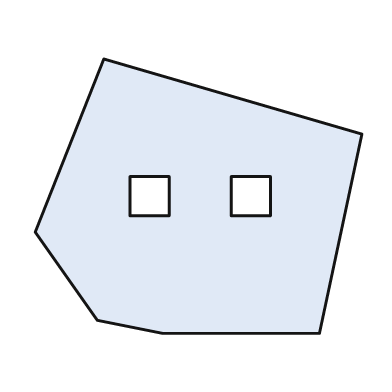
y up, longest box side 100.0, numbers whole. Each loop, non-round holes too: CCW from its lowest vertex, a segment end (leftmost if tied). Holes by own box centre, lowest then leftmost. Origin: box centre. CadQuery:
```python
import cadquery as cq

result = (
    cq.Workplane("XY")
    .moveTo(-11.0, -42.0)
    .lineTo(37.0, -42.0)
    .lineTo(50.0, 19.0)
    .lineTo(-29.0, 42.0)
    .lineTo(-50.0, -11.0)
    .lineTo(-31.0, -38.0)
    .close()
    .moveTo(-21.0, -6.0)
    .lineTo(-9.0, -6.0)
    .lineTo(-9.0, 6.0)
    .lineTo(-21.0, 6.0)
    .close()
    .moveTo(10.0, -6.0)
    .lineTo(22.0, -6.0)
    .lineTo(22.0, 6.0)
    .lineTo(10.0, 6.0)
    .close()
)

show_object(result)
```